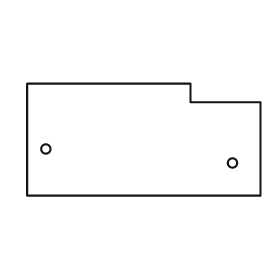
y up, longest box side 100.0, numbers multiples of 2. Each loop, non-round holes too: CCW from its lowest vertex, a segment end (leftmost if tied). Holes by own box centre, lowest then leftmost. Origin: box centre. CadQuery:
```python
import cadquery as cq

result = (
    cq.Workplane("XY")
    .moveTo(-50.0, -24.0)
    .lineTo(50.0, -24.0)
    .lineTo(50.0, 16.0)
    .lineTo(20.0, 16.0)
    .lineTo(20.0, 24.0)
    .lineTo(-50.0, 24.0)
    .close()
    .moveTo(38.0, -10.0)
    .circle(2.0)
    .moveTo(-42.0, -4.0)
    .circle(2.0)
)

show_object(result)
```